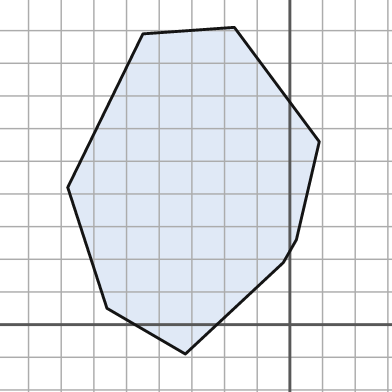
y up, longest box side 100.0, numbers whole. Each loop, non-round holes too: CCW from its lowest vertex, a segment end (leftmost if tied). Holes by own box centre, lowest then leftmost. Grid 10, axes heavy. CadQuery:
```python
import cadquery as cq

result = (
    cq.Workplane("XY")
    .moveTo(-32.0, -9.0)
    .lineTo(-2.0, 19.0)
    .lineTo(2.0, 26.0)
    .lineTo(9.0, 56.0)
    .lineTo(-17.0, 91.0)
    .lineTo(-45.0, 89.0)
    .lineTo(-68.0, 42.0)
    .lineTo(-56.0, 5.0)
    .close()
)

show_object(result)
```